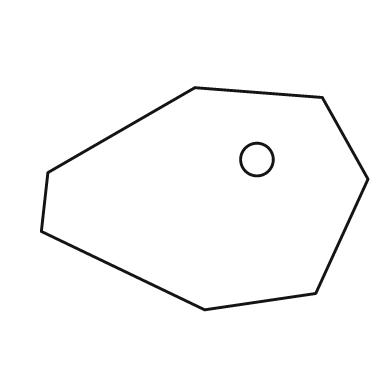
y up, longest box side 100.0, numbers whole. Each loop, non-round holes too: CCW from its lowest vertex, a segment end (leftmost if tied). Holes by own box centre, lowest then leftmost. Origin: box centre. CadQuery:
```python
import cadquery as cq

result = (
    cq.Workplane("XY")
    .moveTo(0.0, -34.0)
    .lineTo(34.0, -29.0)
    .lineTo(50.0, 6.0)
    .lineTo(36.0, 31.0)
    .lineTo(-3.0, 34.0)
    .lineTo(-48.0, 8.0)
    .lineTo(-50.0, -10.0)
    .close()
    .moveTo(16.0, 12.0)
    .circle(5.0)
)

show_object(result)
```